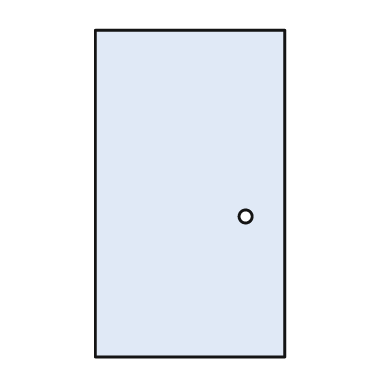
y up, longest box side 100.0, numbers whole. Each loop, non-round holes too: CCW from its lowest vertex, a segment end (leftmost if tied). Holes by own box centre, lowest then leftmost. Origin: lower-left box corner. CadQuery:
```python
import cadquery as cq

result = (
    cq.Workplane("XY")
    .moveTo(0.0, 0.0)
    .lineTo(58.0, 0.0)
    .lineTo(58.0, 100.0)
    .lineTo(0.0, 100.0)
    .close()
    .moveTo(46.0, 43.0)
    .circle(2.0)
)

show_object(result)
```